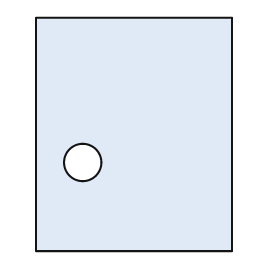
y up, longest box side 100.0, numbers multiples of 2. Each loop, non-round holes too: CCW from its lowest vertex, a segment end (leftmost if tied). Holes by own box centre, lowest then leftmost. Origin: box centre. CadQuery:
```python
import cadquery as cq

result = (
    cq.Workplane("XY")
    .moveTo(-42.0, -50.0)
    .lineTo(42.0, -50.0)
    .lineTo(42.0, 50.0)
    .lineTo(-42.0, 50.0)
    .close()
    .moveTo(-22.0, -12.0)
    .circle(8.0)
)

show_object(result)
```